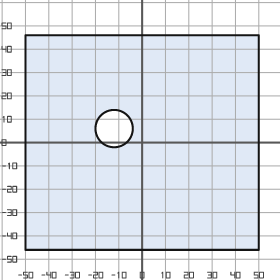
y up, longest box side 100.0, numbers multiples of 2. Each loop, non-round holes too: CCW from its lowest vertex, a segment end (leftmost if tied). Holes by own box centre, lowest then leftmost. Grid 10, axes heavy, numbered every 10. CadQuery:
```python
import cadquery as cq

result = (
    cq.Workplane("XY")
    .moveTo(-50.0, -46.0)
    .lineTo(50.0, -46.0)
    .lineTo(50.0, 46.0)
    .lineTo(-50.0, 46.0)
    .close()
    .moveTo(-12.0, 6.0)
    .circle(8.0)
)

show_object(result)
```